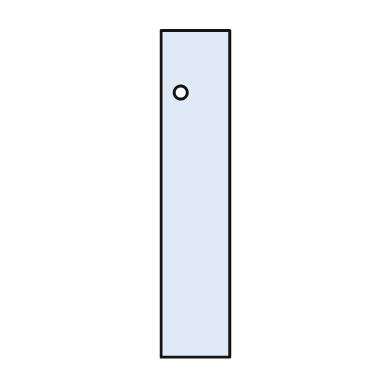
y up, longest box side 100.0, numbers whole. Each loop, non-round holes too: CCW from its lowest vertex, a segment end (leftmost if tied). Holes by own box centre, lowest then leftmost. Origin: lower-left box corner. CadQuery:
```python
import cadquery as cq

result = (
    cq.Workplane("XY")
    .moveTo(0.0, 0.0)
    .lineTo(21.0, 0.0)
    .lineTo(21.0, 100.0)
    .lineTo(0.0, 100.0)
    .close()
    .moveTo(6.0, 81.0)
    .circle(2.0)
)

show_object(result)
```